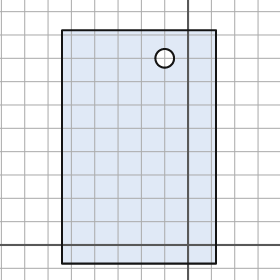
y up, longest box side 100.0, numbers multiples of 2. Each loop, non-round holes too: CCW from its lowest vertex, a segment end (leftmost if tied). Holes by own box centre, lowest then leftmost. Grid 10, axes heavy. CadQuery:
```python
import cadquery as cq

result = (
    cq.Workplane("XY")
    .moveTo(-54.0, -8.0)
    .lineTo(12.0, -8.0)
    .lineTo(12.0, 92.0)
    .lineTo(-54.0, 92.0)
    .close()
    .moveTo(-10.0, 80.0)
    .circle(4.0)
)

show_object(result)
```